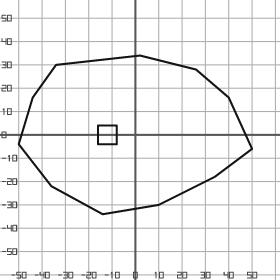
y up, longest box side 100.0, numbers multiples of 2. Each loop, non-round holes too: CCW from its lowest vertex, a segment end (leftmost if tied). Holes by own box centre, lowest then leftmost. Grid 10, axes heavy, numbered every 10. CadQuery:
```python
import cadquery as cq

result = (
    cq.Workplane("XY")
    .moveTo(-14.0, -34.0)
    .lineTo(10.0, -30.0)
    .lineTo(34.0, -18.0)
    .lineTo(50.0, -6.0)
    .lineTo(40.0, 16.0)
    .lineTo(26.0, 28.0)
    .lineTo(2.0, 34.0)
    .lineTo(-34.0, 30.0)
    .lineTo(-44.0, 16.0)
    .lineTo(-50.0, -4.0)
    .lineTo(-36.0, -22.0)
    .close()
    .moveTo(-16.0, -4.0)
    .lineTo(-8.0, -4.0)
    .lineTo(-8.0, 4.0)
    .lineTo(-16.0, 4.0)
    .close()
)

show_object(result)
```